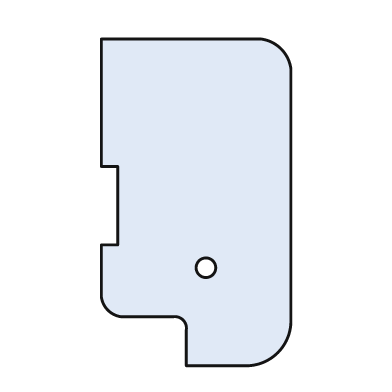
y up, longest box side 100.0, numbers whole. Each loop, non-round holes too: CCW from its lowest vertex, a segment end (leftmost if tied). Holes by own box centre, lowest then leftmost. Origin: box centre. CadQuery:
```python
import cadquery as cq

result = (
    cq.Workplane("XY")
    .moveTo(-3.0, -50.0)
    .lineTo(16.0, -50.0)
    .threePointArc((25.0, -46.0), (29.0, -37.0))
    .lineTo(29.0, 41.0)
    .threePointArc((26.0, 47.0), (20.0, 50.0))
    .lineTo(-29.0, 50.0)
    .lineTo(-29.0, 11.0)
    .lineTo(-24.0, 11.0)
    .lineTo(-24.0, -13.0)
    .lineTo(-29.0, -13.0)
    .lineTo(-29.0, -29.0)
    .threePointArc((-27.0, -33.0), (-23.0, -35.0))
    .lineTo(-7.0, -35.0)
    .threePointArc((-4.0, -36.0), (-3.0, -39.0))
    .close()
    .moveTo(3.0, -20.0)
    .circle(3.0)
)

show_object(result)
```